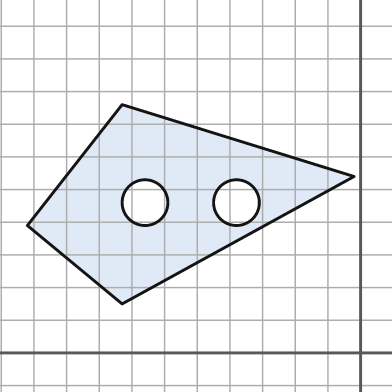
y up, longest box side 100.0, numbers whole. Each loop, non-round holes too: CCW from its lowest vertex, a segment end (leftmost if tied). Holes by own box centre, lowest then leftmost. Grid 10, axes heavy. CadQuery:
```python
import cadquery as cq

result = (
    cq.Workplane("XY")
    .moveTo(-73.0, 15.0)
    .lineTo(-2.0, 54.0)
    .lineTo(-73.0, 76.0)
    .lineTo(-102.0, 39.0)
    .close()
    .moveTo(-66.0, 46.0)
    .circle(7.0)
    .moveTo(-38.0, 46.0)
    .circle(7.0)
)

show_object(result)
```